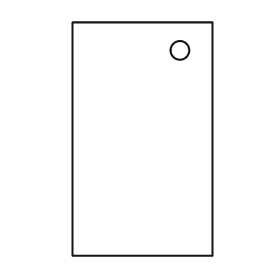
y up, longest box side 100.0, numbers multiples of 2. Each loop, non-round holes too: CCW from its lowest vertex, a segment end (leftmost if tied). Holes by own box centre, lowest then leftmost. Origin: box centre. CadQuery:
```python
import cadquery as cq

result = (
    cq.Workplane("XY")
    .moveTo(-30.0, -50.0)
    .lineTo(30.0, -50.0)
    .lineTo(30.0, 50.0)
    .lineTo(-30.0, 50.0)
    .close()
    .moveTo(16.0, 38.0)
    .circle(4.0)
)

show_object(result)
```